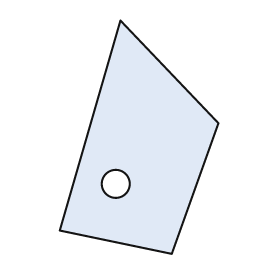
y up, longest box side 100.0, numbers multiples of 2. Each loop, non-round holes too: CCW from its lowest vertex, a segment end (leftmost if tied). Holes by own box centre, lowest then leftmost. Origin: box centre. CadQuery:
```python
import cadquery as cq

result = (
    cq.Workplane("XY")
    .moveTo(14.0, -50.0)
    .lineTo(34.0, 6.0)
    .lineTo(-8.0, 50.0)
    .lineTo(-34.0, -40.0)
    .close()
    .moveTo(-10.0, -20.0)
    .circle(6.0)
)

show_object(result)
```